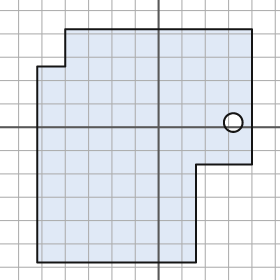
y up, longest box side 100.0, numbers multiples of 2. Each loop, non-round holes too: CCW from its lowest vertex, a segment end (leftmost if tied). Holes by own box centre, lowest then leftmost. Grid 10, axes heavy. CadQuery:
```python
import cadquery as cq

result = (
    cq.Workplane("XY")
    .moveTo(-52.0, -58.0)
    .lineTo(16.0, -58.0)
    .lineTo(16.0, -16.0)
    .lineTo(40.0, -16.0)
    .lineTo(40.0, 42.0)
    .lineTo(-40.0, 42.0)
    .lineTo(-40.0, 26.0)
    .lineTo(-52.0, 26.0)
    .close()
    .moveTo(32.0, 2.0)
    .circle(4.0)
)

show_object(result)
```